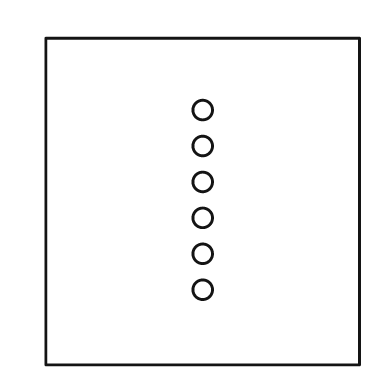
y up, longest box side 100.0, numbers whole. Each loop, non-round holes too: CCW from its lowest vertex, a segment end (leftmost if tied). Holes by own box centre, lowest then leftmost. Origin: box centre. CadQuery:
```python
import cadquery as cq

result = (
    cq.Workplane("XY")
    .moveTo(-48.0, -50.0)
    .lineTo(48.0, -50.0)
    .lineTo(48.0, 50.0)
    .lineTo(-48.0, 50.0)
    .close()
    .moveTo(0.0, -27.0)
    .circle(3.0)
    .moveTo(0.0, -16.0)
    .circle(3.0)
    .moveTo(0.0, -5.0)
    .circle(3.0)
    .moveTo(0.0, 6.0)
    .circle(3.0)
    .moveTo(0.0, 17.0)
    .circle(3.0)
    .moveTo(0.0, 28.0)
    .circle(3.0)
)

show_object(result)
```